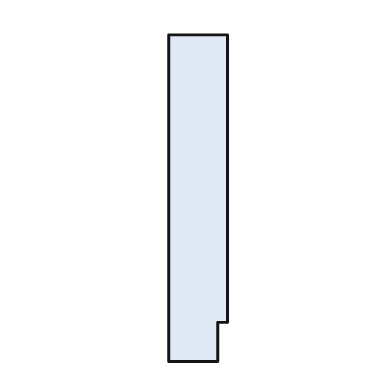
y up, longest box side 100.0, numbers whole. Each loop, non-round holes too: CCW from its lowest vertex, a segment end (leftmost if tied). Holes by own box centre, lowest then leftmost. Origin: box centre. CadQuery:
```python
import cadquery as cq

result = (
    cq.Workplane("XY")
    .moveTo(-9.0, -50.0)
    .lineTo(6.0, -50.0)
    .lineTo(6.0, -38.0)
    .lineTo(9.0, -38.0)
    .lineTo(9.0, 50.0)
    .lineTo(-9.0, 50.0)
    .close()
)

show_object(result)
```